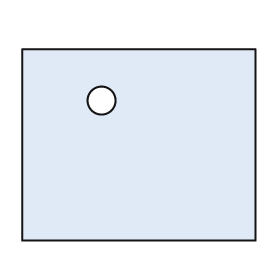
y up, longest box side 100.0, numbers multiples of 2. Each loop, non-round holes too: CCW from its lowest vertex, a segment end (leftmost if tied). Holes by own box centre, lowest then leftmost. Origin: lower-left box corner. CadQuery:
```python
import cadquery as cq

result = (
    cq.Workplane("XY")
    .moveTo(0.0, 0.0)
    .lineTo(100.0, 0.0)
    .lineTo(100.0, 82.0)
    .lineTo(0.0, 82.0)
    .close()
    .moveTo(34.0, 60.0)
    .circle(6.0)
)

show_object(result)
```